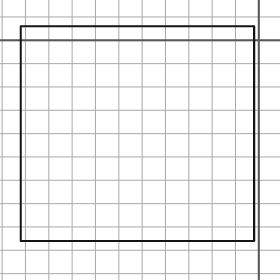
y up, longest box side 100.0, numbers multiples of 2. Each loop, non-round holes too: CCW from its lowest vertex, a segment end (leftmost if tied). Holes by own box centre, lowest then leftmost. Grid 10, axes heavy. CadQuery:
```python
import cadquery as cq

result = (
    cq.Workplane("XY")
    .moveTo(-102.0, -86.0)
    .lineTo(-2.0, -86.0)
    .lineTo(-2.0, 6.0)
    .lineTo(-102.0, 6.0)
    .close()
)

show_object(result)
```